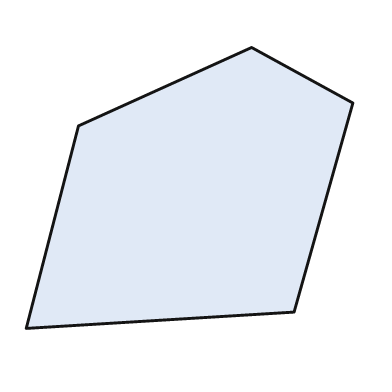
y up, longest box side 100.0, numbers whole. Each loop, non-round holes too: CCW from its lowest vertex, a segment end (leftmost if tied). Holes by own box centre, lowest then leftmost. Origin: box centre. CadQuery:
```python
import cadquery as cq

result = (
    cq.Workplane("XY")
    .moveTo(-50.0, -43.0)
    .lineTo(32.0, -38.0)
    .lineTo(50.0, 26.0)
    .lineTo(19.0, 43.0)
    .lineTo(-34.0, 19.0)
    .close()
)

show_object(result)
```